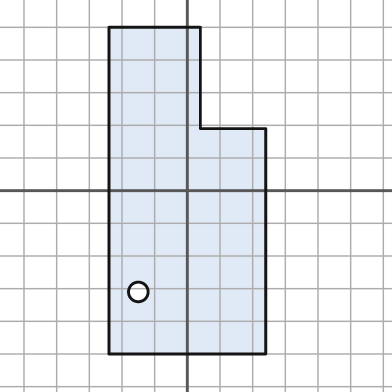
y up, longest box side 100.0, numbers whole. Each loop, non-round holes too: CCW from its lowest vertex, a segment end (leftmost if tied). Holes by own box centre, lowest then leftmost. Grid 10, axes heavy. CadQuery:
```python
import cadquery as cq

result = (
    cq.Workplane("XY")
    .moveTo(-24.0, -50.0)
    .lineTo(24.0, -50.0)
    .lineTo(24.0, 19.0)
    .lineTo(4.0, 19.0)
    .lineTo(4.0, 50.0)
    .lineTo(-24.0, 50.0)
    .close()
    .moveTo(-15.0, -31.0)
    .circle(3.0)
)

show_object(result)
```